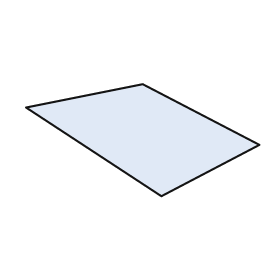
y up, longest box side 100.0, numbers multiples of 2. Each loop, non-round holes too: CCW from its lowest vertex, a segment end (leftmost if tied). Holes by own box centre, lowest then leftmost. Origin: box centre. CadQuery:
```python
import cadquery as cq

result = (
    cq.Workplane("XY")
    .moveTo(8.0, -24.0)
    .lineTo(50.0, -2.0)
    .lineTo(0.0, 24.0)
    .lineTo(-50.0, 14.0)
    .close()
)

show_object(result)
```